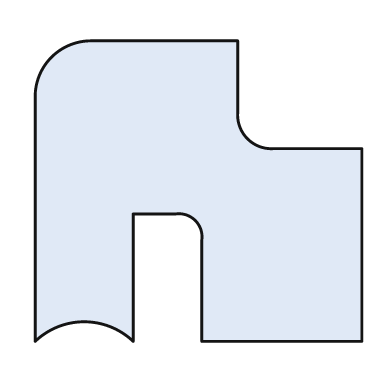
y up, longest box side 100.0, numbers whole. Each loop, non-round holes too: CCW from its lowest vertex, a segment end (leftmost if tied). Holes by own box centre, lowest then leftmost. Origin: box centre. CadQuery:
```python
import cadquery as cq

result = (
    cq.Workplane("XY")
    .moveTo(-50.0, -46.0)
    .threePointArc((-35.0, -40.0), (-20.0, -46.0))
    .lineTo(-20.0, -7.0)
    .lineTo(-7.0, -7.0)
    .threePointArc((-1.0, -9.0), (1.0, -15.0))
    .lineTo(1.0, -46.0)
    .lineTo(50.0, -46.0)
    .lineTo(50.0, 13.0)
    .lineTo(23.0, 13.0)
    .threePointArc((15.0, 16.0), (12.0, 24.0))
    .lineTo(12.0, 46.0)
    .lineTo(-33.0, 46.0)
    .threePointArc((-45.0, 41.0), (-50.0, 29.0))
    .close()
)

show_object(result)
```